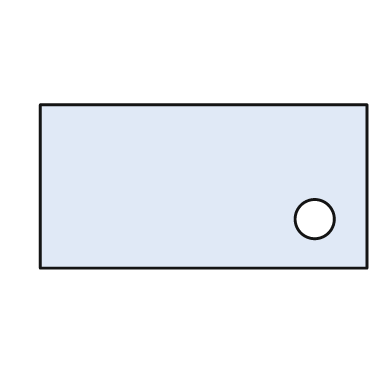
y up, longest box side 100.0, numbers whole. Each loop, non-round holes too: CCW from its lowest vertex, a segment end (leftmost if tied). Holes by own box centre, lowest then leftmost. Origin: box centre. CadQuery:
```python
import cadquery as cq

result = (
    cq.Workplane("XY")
    .moveTo(-50.0, -25.0)
    .lineTo(50.0, -25.0)
    .lineTo(50.0, 25.0)
    .lineTo(-50.0, 25.0)
    .close()
    .moveTo(34.0, -10.0)
    .circle(6.0)
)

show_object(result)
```